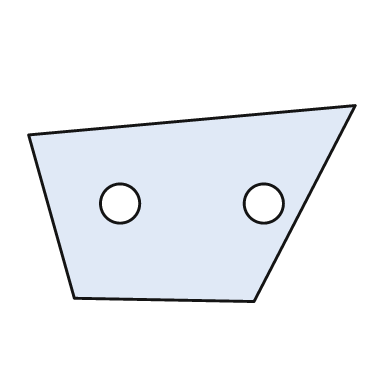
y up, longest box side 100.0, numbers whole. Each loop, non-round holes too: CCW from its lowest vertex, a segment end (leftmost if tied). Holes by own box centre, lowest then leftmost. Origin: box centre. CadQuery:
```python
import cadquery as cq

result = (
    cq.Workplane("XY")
    .moveTo(19.0, -30.0)
    .lineTo(50.0, 30.0)
    .lineTo(-50.0, 21.0)
    .lineTo(-36.0, -29.0)
    .close()
    .moveTo(-22.0, 0.0)
    .circle(6.0)
    .moveTo(22.0, 0.0)
    .circle(6.0)
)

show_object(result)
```